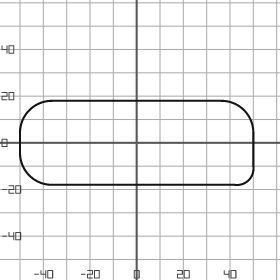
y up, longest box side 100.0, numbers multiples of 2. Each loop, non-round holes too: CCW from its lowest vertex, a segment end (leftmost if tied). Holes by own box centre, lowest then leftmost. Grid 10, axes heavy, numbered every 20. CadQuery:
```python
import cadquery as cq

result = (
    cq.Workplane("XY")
    .moveTo(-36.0, -18.0)
    .lineTo(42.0, -18.0)
    .threePointArc((48.0, -16.0), (50.0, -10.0))
    .lineTo(50.0, 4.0)
    .threePointArc((46.0, 14.0), (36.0, 18.0))
    .lineTo(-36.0, 18.0)
    .threePointArc((-46.0, 14.0), (-50.0, 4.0))
    .lineTo(-50.0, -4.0)
    .threePointArc((-46.0, -14.0), (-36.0, -18.0))
    .close()
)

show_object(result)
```